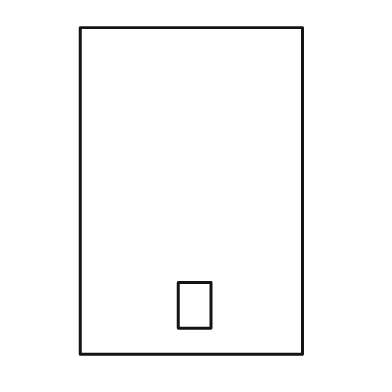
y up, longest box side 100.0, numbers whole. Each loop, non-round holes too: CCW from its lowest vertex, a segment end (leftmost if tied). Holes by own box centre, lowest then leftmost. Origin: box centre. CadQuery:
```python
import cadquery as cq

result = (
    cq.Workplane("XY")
    .moveTo(-34.0, -50.0)
    .lineTo(34.0, -50.0)
    .lineTo(34.0, 50.0)
    .lineTo(-34.0, 50.0)
    .close()
    .moveTo(-4.0, -42.0)
    .lineTo(6.0, -42.0)
    .lineTo(6.0, -28.0)
    .lineTo(-4.0, -28.0)
    .close()
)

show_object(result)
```